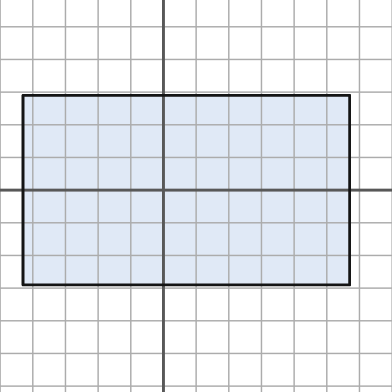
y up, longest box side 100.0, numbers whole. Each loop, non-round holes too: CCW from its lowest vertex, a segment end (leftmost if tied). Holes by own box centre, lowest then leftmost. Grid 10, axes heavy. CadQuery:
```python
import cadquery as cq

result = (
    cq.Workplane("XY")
    .moveTo(-43.0, -29.0)
    .lineTo(57.0, -29.0)
    .lineTo(57.0, 29.0)
    .lineTo(-43.0, 29.0)
    .close()
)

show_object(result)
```